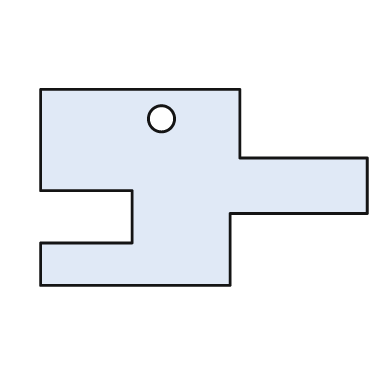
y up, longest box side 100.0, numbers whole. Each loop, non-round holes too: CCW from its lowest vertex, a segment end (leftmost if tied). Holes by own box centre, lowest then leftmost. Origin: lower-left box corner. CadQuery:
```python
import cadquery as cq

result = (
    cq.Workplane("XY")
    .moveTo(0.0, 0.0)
    .lineTo(58.0, 0.0)
    .lineTo(58.0, 22.0)
    .lineTo(100.0, 22.0)
    .lineTo(100.0, 39.0)
    .lineTo(61.0, 39.0)
    .lineTo(61.0, 60.0)
    .lineTo(0.0, 60.0)
    .lineTo(0.0, 29.0)
    .lineTo(28.0, 29.0)
    .lineTo(28.0, 13.0)
    .lineTo(0.0, 13.0)
    .close()
    .moveTo(37.0, 51.0)
    .circle(4.0)
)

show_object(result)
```